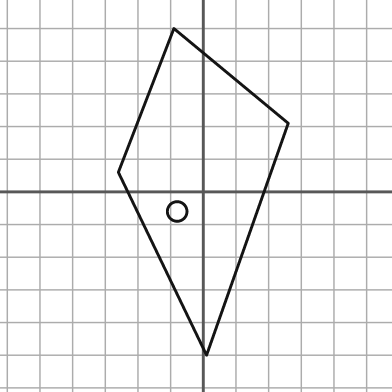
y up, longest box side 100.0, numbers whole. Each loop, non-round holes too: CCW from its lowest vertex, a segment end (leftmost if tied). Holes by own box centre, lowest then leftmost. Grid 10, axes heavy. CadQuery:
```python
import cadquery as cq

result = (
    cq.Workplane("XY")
    .moveTo(1.0, -50.0)
    .lineTo(26.0, 21.0)
    .lineTo(-9.0, 50.0)
    .lineTo(-26.0, 6.0)
    .close()
    .moveTo(-8.0, -6.0)
    .circle(3.0)
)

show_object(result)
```